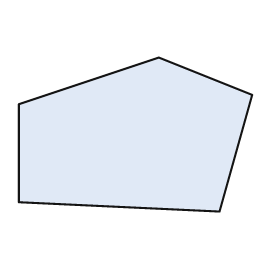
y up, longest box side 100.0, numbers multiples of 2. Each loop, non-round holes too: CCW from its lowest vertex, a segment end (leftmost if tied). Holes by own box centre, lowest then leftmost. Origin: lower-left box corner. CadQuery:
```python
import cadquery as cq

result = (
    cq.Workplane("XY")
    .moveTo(86.0, 0.0)
    .lineTo(100.0, 50.0)
    .lineTo(60.0, 66.0)
    .lineTo(0.0, 46.0)
    .lineTo(0.0, 4.0)
    .close()
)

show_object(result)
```